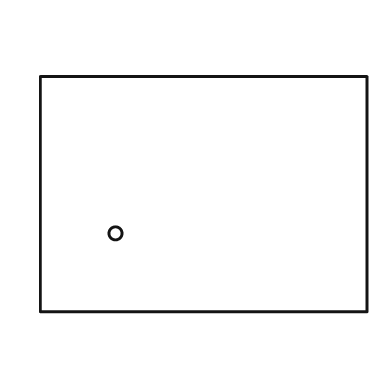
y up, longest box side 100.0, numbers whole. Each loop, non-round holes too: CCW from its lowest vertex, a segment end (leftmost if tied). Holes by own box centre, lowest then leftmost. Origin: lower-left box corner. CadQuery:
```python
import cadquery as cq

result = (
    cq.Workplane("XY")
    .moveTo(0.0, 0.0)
    .lineTo(100.0, 0.0)
    .lineTo(100.0, 72.0)
    .lineTo(0.0, 72.0)
    .close()
    .moveTo(23.0, 24.0)
    .circle(2.0)
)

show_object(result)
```